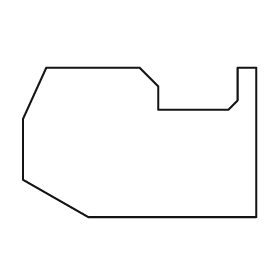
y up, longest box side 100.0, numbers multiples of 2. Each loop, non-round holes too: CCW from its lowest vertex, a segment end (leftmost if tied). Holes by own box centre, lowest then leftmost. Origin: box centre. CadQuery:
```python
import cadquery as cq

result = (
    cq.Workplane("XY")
    .moveTo(-22.0, -32.0)
    .lineTo(50.0, -32.0)
    .lineTo(50.0, 32.0)
    .lineTo(42.0, 32.0)
    .lineTo(42.0, 18.0)
    .lineTo(38.0, 14.0)
    .lineTo(8.0, 14.0)
    .lineTo(8.0, 24.0)
    .lineTo(0.0, 32.0)
    .lineTo(-40.0, 32.0)
    .lineTo(-50.0, 10.0)
    .lineTo(-50.0, -16.0)
    .close()
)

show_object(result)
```